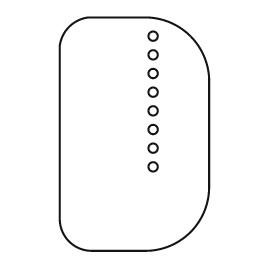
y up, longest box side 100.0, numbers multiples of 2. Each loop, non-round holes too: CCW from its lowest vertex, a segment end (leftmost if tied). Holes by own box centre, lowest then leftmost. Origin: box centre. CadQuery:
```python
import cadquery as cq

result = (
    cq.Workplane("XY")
    .moveTo(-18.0, -50.0)
    .lineTo(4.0, -50.0)
    .threePointArc((24.0, -42.0), (32.0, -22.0))
    .lineTo(32.0, 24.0)
    .threePointArc((24.0, 42.0), (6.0, 50.0))
    .lineTo(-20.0, 50.0)
    .threePointArc((-28.0, 46.0), (-32.0, 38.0))
    .lineTo(-32.0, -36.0)
    .threePointArc((-28.0, -46.0), (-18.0, -50.0))
    .close()
    .moveTo(8.0, -14.0)
    .circle(2.0)
    .moveTo(8.0, -6.0)
    .circle(2.0)
    .moveTo(8.0, 2.0)
    .circle(2.0)
    .moveTo(8.0, 10.0)
    .circle(2.0)
    .moveTo(8.0, 18.0)
    .circle(2.0)
    .moveTo(8.0, 26.0)
    .circle(2.0)
    .moveTo(8.0, 34.0)
    .circle(2.0)
    .moveTo(8.0, 42.0)
    .circle(2.0)
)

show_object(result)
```